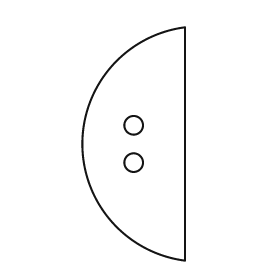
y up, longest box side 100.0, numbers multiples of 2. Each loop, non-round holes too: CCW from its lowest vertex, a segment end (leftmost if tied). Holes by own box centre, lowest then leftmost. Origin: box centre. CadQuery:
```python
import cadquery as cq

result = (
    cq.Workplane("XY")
    .moveTo(22.0, -50.0)
    .lineTo(22.0, 50.0)
    .threePointArc((-22.0, 0.0), (22.0, -50.0))
    .close()
    .moveTo(0.0, -8.0)
    .circle(4.0)
    .moveTo(0.0, 8.0)
    .circle(4.0)
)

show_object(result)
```